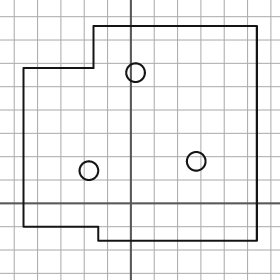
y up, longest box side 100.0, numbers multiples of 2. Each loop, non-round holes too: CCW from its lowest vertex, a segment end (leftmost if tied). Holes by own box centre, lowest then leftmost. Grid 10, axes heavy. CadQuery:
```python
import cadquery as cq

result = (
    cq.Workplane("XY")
    .moveTo(-14.0, -16.0)
    .lineTo(54.0, -16.0)
    .lineTo(54.0, 76.0)
    .lineTo(-16.0, 76.0)
    .lineTo(-16.0, 58.0)
    .lineTo(-46.0, 58.0)
    .lineTo(-46.0, -10.0)
    .lineTo(-14.0, -10.0)
    .close()
    .moveTo(-18.0, 14.0)
    .circle(4.0)
    .moveTo(28.0, 18.0)
    .circle(4.0)
    .moveTo(2.0, 56.0)
    .circle(4.0)
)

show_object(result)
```